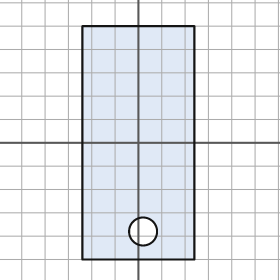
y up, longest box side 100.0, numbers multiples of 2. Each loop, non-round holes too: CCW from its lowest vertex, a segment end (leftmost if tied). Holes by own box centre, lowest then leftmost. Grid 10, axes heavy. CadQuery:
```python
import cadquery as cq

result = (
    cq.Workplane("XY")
    .moveTo(-24.0, -50.0)
    .lineTo(24.0, -50.0)
    .lineTo(24.0, 50.0)
    .lineTo(-24.0, 50.0)
    .close()
    .moveTo(2.0, -38.0)
    .circle(6.0)
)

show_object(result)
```